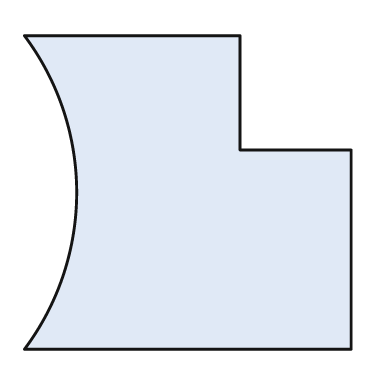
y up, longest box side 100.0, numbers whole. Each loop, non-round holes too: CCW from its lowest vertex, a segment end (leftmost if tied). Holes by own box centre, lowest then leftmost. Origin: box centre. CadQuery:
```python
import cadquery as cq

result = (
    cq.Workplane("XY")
    .moveTo(-50.0, -48.0)
    .lineTo(50.0, -48.0)
    .lineTo(50.0, 13.0)
    .lineTo(16.0, 13.0)
    .lineTo(16.0, 48.0)
    .lineTo(-50.0, 48.0)
    .threePointArc((-34.0, 0.0), (-50.0, -48.0))
    .close()
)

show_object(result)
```